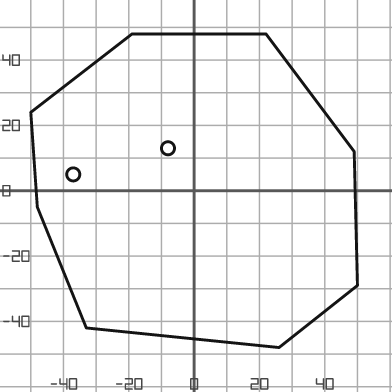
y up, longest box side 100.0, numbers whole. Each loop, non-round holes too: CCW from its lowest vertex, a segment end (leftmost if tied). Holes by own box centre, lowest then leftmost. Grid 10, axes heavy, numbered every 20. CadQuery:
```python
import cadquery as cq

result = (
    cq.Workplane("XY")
    .moveTo(26.0, -48.0)
    .lineTo(50.0, -29.0)
    .lineTo(49.0, 12.0)
    .lineTo(22.0, 48.0)
    .lineTo(-19.0, 48.0)
    .lineTo(-50.0, 24.0)
    .lineTo(-48.0, -5.0)
    .lineTo(-33.0, -42.0)
    .close()
    .moveTo(-37.0, 5.0)
    .circle(2.0)
    .moveTo(-8.0, 13.0)
    .circle(2.0)
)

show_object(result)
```